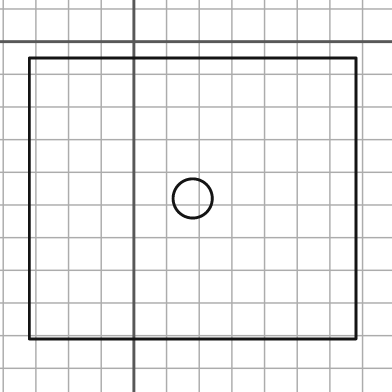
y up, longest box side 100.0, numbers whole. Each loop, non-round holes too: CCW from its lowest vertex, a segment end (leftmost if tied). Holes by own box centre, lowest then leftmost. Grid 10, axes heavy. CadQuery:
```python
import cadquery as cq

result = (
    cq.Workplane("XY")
    .moveTo(-32.0, -91.0)
    .lineTo(68.0, -91.0)
    .lineTo(68.0, -5.0)
    .lineTo(-32.0, -5.0)
    .close()
    .moveTo(18.0, -48.0)
    .circle(6.0)
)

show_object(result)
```